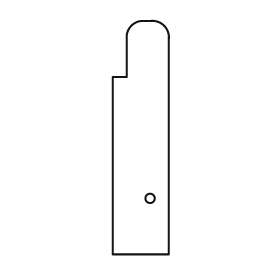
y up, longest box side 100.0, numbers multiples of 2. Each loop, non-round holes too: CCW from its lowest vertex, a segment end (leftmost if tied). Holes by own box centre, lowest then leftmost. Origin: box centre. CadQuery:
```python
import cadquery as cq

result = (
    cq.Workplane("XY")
    .moveTo(-12.0, -50.0)
    .lineTo(12.0, -50.0)
    .lineTo(12.0, 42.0)
    .threePointArc((10.0, 48.0), (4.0, 50.0))
    .lineTo(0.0, 50.0)
    .threePointArc((-4.0, 48.0), (-6.0, 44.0))
    .lineTo(-6.0, 26.0)
    .lineTo(-12.0, 26.0)
    .close()
    .moveTo(4.0, -26.0)
    .circle(2.0)
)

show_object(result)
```